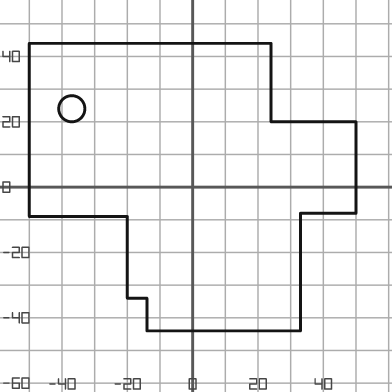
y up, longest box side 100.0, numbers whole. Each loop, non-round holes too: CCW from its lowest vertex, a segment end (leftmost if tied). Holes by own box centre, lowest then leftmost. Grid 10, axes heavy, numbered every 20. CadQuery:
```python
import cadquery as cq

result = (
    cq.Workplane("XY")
    .moveTo(-14.0, -44.0)
    .lineTo(33.0, -44.0)
    .lineTo(33.0, -8.0)
    .lineTo(50.0, -8.0)
    .lineTo(50.0, 20.0)
    .lineTo(24.0, 20.0)
    .lineTo(24.0, 44.0)
    .lineTo(-50.0, 44.0)
    .lineTo(-50.0, -9.0)
    .lineTo(-20.0, -9.0)
    .lineTo(-20.0, -34.0)
    .lineTo(-14.0, -34.0)
    .close()
    .moveTo(-37.0, 24.0)
    .circle(4.0)
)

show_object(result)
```